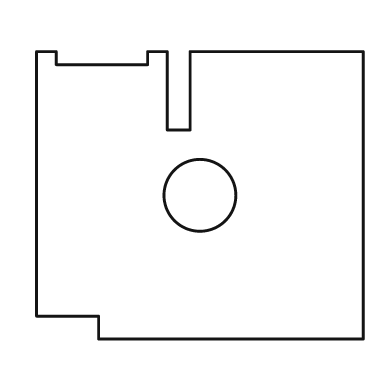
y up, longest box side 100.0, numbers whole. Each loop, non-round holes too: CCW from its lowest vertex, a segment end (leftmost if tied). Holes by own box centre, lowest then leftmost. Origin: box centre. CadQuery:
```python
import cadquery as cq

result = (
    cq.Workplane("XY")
    .moveTo(-31.0, -44.0)
    .lineTo(50.0, -44.0)
    .lineTo(50.0, 44.0)
    .lineTo(-3.0, 44.0)
    .lineTo(-3.0, 20.0)
    .lineTo(-10.0, 20.0)
    .lineTo(-10.0, 44.0)
    .lineTo(-16.0, 44.0)
    .lineTo(-16.0, 40.0)
    .lineTo(-44.0, 40.0)
    .lineTo(-44.0, 44.0)
    .lineTo(-50.0, 44.0)
    .lineTo(-50.0, -37.0)
    .lineTo(-31.0, -37.0)
    .close()
    .moveTo(0.0, 0.0)
    .circle(11.0)
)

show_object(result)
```